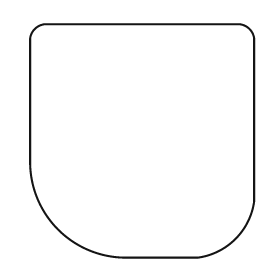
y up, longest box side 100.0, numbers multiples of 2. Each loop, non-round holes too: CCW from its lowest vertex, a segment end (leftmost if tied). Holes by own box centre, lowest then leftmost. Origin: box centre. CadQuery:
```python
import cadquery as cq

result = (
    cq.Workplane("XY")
    .moveTo(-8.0, -50.0)
    .lineTo(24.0, -50.0)
    .threePointArc((40.0, -42.0), (48.0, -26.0))
    .lineTo(48.0, 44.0)
    .threePointArc((46.0, 48.0), (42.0, 50.0))
    .lineTo(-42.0, 50.0)
    .threePointArc((-46.0, 48.0), (-48.0, 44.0))
    .lineTo(-48.0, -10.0)
    .threePointArc((-36.0, -38.0), (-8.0, -50.0))
    .close()
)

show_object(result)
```